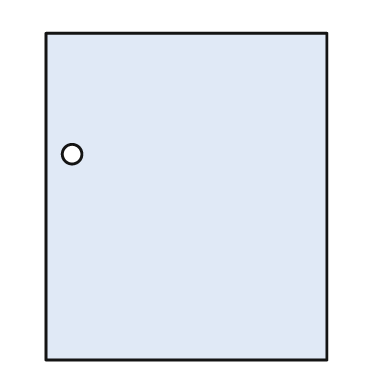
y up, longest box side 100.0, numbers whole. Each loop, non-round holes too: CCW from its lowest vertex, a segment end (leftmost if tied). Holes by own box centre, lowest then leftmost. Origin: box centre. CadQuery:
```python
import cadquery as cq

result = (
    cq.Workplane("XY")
    .moveTo(-43.0, -50.0)
    .lineTo(43.0, -50.0)
    .lineTo(43.0, 50.0)
    .lineTo(-43.0, 50.0)
    .close()
    .moveTo(-35.0, 13.0)
    .circle(3.0)
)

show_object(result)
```